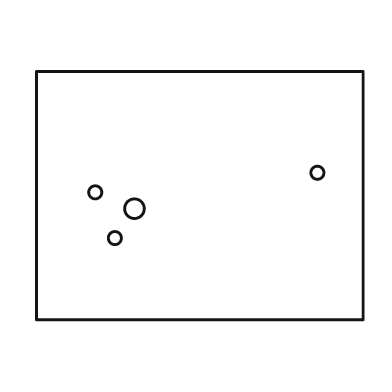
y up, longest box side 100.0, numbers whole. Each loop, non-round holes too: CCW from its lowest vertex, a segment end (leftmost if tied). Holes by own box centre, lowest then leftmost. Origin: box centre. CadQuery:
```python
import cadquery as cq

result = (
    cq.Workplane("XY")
    .moveTo(-50.0, -38.0)
    .lineTo(50.0, -38.0)
    .lineTo(50.0, 38.0)
    .lineTo(-50.0, 38.0)
    .close()
    .moveTo(-26.0, -13.0)
    .circle(2.0)
    .moveTo(-20.0, -4.0)
    .circle(3.0)
    .moveTo(-32.0, 1.0)
    .circle(2.0)
    .moveTo(36.0, 7.0)
    .circle(2.0)
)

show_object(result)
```